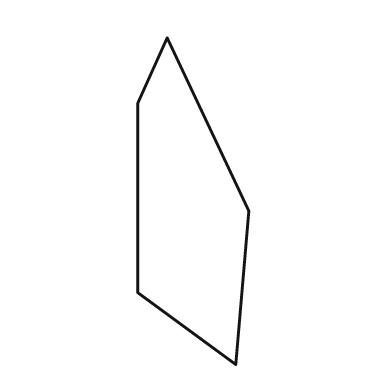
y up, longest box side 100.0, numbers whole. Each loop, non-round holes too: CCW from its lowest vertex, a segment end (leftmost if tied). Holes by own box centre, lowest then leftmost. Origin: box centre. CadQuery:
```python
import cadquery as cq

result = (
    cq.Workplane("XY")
    .moveTo(13.0, -50.0)
    .lineTo(17.0, -3.0)
    .lineTo(-8.0, 50.0)
    .lineTo(-17.0, 30.0)
    .lineTo(-17.0, -28.0)
    .close()
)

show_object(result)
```